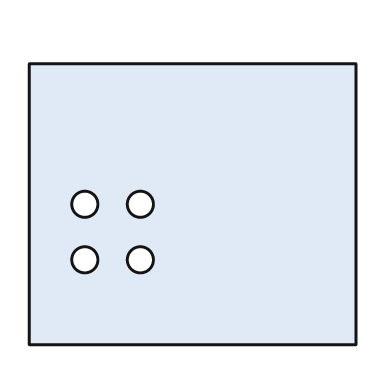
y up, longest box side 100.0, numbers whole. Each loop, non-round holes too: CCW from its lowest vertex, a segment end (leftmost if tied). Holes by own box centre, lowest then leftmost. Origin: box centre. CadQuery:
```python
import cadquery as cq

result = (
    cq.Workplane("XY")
    .moveTo(-50.0, -43.0)
    .lineTo(50.0, -43.0)
    .lineTo(50.0, 43.0)
    .lineTo(-50.0, 43.0)
    .close()
    .moveTo(-33.0, -17.0)
    .circle(4.0)
    .moveTo(-16.0, -17.0)
    .circle(4.0)
    .moveTo(-33.0, 0.0)
    .circle(4.0)
    .moveTo(-16.0, 0.0)
    .circle(4.0)
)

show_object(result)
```